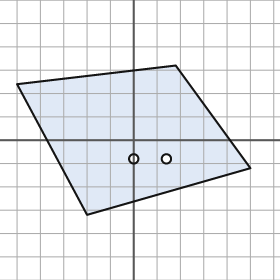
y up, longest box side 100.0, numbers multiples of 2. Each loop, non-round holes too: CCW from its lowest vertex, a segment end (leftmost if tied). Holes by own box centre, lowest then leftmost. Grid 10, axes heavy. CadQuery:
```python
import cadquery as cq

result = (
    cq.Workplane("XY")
    .moveTo(-20.0, -32.0)
    .lineTo(50.0, -12.0)
    .lineTo(18.0, 32.0)
    .lineTo(-50.0, 24.0)
    .close()
    .moveTo(0.0, -8.0)
    .circle(2.0)
    .moveTo(14.0, -8.0)
    .circle(2.0)
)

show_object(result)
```